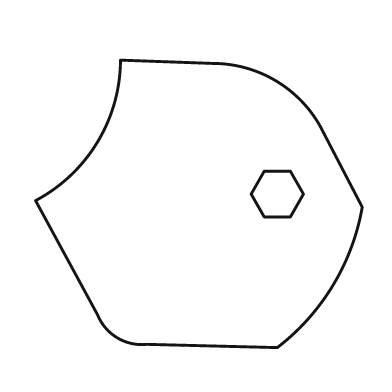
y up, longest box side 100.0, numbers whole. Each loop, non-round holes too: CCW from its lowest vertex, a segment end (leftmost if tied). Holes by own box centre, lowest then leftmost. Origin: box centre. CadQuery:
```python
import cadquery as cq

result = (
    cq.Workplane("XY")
    .moveTo(24.0, -44.0)
    .threePointArc((41.0, -25.0), (50.0, -1.0))
    .lineTo(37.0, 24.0)
    .threePointArc((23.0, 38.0), (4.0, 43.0))
    .lineTo(-24.0, 44.0)
    .threePointArc((-31.0, 19.0), (-50.0, 1.0))
    .lineTo(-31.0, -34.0)
    .threePointArc((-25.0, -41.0), (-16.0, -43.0))
    .close()
    .moveTo(20.0, -4.0)
    .lineTo(28.0, -4.0)
    .lineTo(32.0, 3.0)
    .lineTo(28.0, 10.0)
    .lineTo(20.0, 10.0)
    .lineTo(16.0, 3.0)
    .close()
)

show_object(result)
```